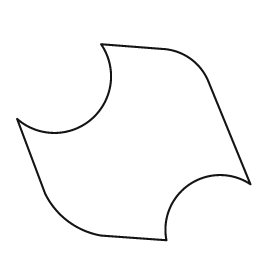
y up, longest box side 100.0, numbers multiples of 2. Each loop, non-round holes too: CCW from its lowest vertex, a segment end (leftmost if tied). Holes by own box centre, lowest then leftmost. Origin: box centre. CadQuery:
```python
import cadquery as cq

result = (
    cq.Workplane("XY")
    .moveTo(14.0, -42.0)
    .threePointArc((24.0, -18.0), (50.0, -18.0))
    .lineTo(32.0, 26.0)
    .threePointArc((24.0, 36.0), (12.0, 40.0))
    .lineTo(-14.0, 42.0)
    .threePointArc((-18.0, 10.0), (-50.0, 10.0))
    .lineTo(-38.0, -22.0)
    .threePointArc((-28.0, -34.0), (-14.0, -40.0))
    .close()
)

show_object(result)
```